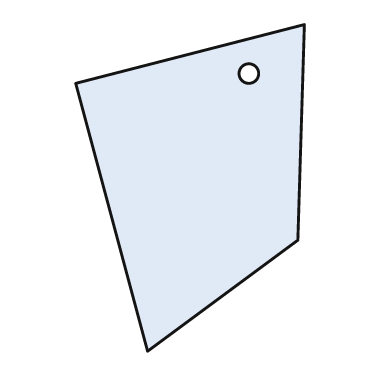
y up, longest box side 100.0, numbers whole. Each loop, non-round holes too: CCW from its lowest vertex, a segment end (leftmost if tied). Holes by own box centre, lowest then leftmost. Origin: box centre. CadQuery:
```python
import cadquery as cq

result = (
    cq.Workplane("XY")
    .moveTo(-13.0, -50.0)
    .lineTo(33.0, -16.0)
    .lineTo(35.0, 50.0)
    .lineTo(-35.0, 32.0)
    .close()
    .moveTo(18.0, 35.0)
    .circle(3.0)
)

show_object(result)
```